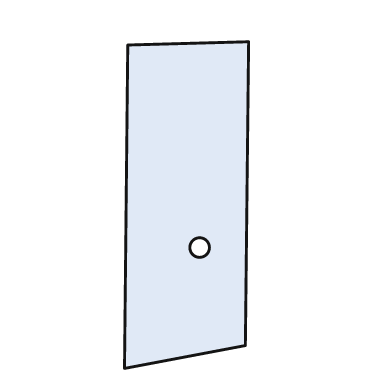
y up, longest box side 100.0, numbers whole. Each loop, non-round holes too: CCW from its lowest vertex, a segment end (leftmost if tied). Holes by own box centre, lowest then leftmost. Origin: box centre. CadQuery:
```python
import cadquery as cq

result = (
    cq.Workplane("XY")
    .moveTo(-19.0, -50.0)
    .lineTo(18.0, -43.0)
    .lineTo(19.0, 50.0)
    .lineTo(-18.0, 49.0)
    .close()
    .moveTo(4.0, -13.0)
    .circle(3.0)
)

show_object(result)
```